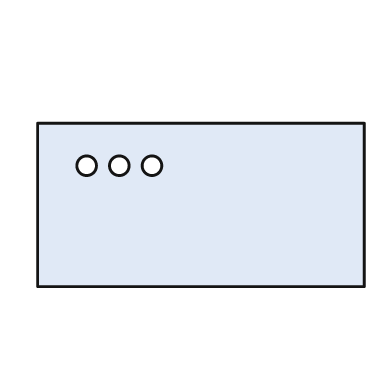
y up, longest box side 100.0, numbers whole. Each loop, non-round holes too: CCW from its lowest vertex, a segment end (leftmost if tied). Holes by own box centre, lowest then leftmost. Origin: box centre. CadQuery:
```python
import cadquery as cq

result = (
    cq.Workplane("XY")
    .moveTo(-50.0, -25.0)
    .lineTo(50.0, -25.0)
    .lineTo(50.0, 25.0)
    .lineTo(-50.0, 25.0)
    .close()
    .moveTo(-35.0, 12.0)
    .circle(3.0)
    .moveTo(-25.0, 12.0)
    .circle(3.0)
    .moveTo(-15.0, 12.0)
    .circle(3.0)
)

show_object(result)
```